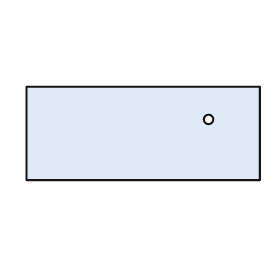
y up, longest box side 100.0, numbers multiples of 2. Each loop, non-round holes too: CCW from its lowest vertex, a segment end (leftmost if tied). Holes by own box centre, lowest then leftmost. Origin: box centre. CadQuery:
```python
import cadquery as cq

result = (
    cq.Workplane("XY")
    .moveTo(-50.0, -20.0)
    .lineTo(50.0, -20.0)
    .lineTo(50.0, 20.0)
    .lineTo(-50.0, 20.0)
    .close()
    .moveTo(28.0, 6.0)
    .circle(2.0)
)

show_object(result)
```